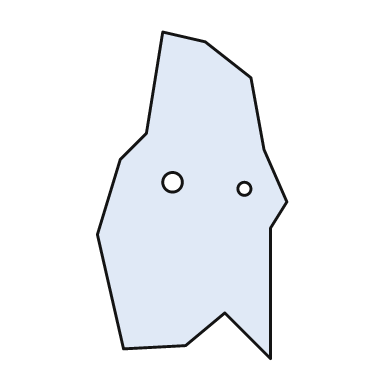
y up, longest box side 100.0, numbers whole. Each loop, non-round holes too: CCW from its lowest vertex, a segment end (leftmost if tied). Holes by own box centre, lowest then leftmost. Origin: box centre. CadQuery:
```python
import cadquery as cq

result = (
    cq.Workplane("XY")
    .moveTo(24.0, -50.0)
    .lineTo(24.0, -10.0)
    .lineTo(29.0, -2.0)
    .lineTo(22.0, 14.0)
    .lineTo(18.0, 36.0)
    .lineTo(4.0, 47.0)
    .lineTo(-9.0, 50.0)
    .lineTo(-14.0, 19.0)
    .lineTo(-22.0, 11.0)
    .lineTo(-29.0, -12.0)
    .lineTo(-21.0, -47.0)
    .lineTo(-2.0, -46.0)
    .lineTo(10.0, -36.0)
    .close()
    .moveTo(16.0, 2.0)
    .circle(2.0)
    .moveTo(-6.0, 4.0)
    .circle(3.0)
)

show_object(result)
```